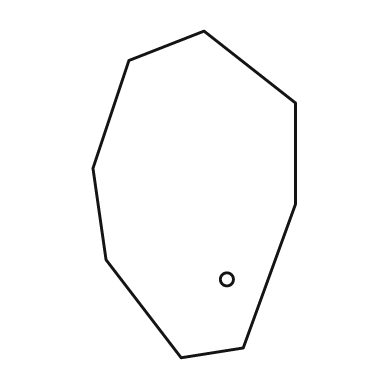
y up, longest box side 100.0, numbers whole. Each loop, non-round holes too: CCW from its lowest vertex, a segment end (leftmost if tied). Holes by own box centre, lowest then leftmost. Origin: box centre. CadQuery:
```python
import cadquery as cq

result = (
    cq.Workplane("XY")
    .moveTo(-4.0, -50.0)
    .lineTo(15.0, -47.0)
    .lineTo(31.0, -3.0)
    .lineTo(31.0, 28.0)
    .lineTo(3.0, 50.0)
    .lineTo(-20.0, 41.0)
    .lineTo(-31.0, 8.0)
    .lineTo(-27.0, -20.0)
    .close()
    .moveTo(10.0, -26.0)
    .circle(2.0)
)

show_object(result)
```